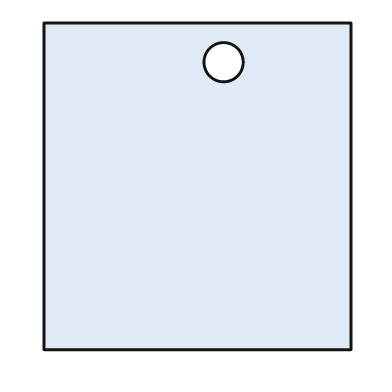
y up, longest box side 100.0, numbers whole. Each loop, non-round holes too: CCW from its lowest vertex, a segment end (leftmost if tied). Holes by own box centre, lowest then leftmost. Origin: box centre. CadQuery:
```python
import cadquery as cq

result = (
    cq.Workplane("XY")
    .moveTo(-47.0, -50.0)
    .lineTo(47.0, -50.0)
    .lineTo(47.0, 50.0)
    .lineTo(-47.0, 50.0)
    .close()
    .moveTo(8.0, 38.0)
    .circle(6.0)
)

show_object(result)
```